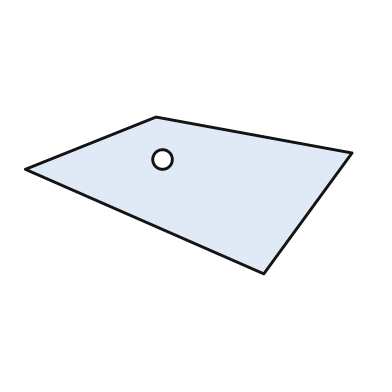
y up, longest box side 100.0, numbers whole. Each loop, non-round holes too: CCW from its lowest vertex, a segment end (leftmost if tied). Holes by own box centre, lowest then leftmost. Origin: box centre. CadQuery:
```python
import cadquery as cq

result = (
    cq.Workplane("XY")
    .moveTo(23.0, -24.0)
    .lineTo(50.0, 13.0)
    .lineTo(-10.0, 24.0)
    .lineTo(-50.0, 8.0)
    .close()
    .moveTo(-8.0, 11.0)
    .circle(3.0)
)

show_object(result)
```